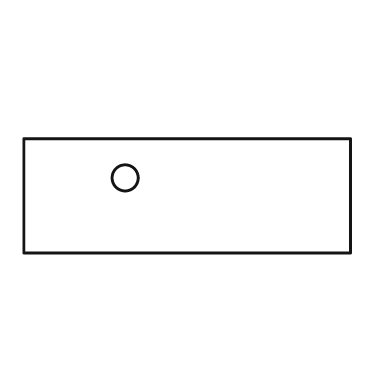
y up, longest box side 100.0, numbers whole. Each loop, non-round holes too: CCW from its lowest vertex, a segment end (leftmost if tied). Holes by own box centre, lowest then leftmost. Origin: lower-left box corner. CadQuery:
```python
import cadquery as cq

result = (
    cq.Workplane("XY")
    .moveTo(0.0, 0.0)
    .lineTo(100.0, 0.0)
    .lineTo(100.0, 35.0)
    .lineTo(0.0, 35.0)
    .close()
    .moveTo(31.0, 23.0)
    .circle(4.0)
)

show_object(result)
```